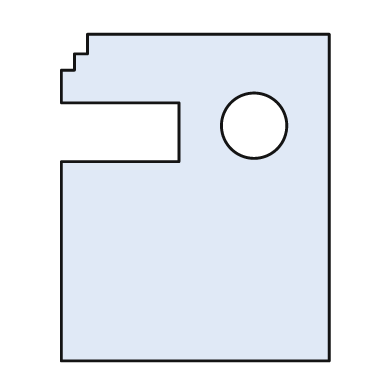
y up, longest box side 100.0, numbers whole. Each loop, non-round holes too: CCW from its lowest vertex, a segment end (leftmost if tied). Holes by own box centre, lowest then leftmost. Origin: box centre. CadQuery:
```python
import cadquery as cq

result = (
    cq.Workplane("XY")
    .moveTo(-41.0, -50.0)
    .lineTo(41.0, -50.0)
    .lineTo(41.0, 50.0)
    .lineTo(-33.0, 50.0)
    .lineTo(-33.0, 44.0)
    .lineTo(-37.0, 44.0)
    .lineTo(-37.0, 39.0)
    .lineTo(-41.0, 39.0)
    .lineTo(-41.0, 29.0)
    .lineTo(-5.0, 29.0)
    .lineTo(-5.0, 11.0)
    .lineTo(-41.0, 11.0)
    .close()
    .moveTo(18.0, 22.0)
    .circle(10.0)
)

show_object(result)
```